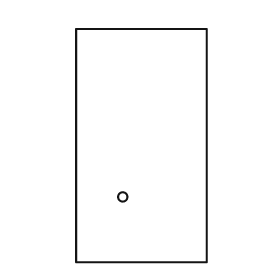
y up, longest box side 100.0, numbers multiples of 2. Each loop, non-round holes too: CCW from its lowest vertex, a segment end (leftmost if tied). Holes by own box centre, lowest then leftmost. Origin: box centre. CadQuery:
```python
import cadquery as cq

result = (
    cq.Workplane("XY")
    .moveTo(-28.0, -50.0)
    .lineTo(28.0, -50.0)
    .lineTo(28.0, 50.0)
    .lineTo(-28.0, 50.0)
    .close()
    .moveTo(-8.0, -22.0)
    .circle(2.0)
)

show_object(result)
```